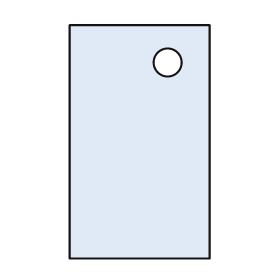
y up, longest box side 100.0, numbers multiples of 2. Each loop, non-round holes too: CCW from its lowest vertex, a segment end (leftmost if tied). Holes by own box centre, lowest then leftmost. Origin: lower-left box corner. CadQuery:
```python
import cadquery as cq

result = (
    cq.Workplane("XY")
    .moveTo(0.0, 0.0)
    .lineTo(60.0, 0.0)
    .lineTo(60.0, 100.0)
    .lineTo(0.0, 100.0)
    .close()
    .moveTo(42.0, 84.0)
    .circle(6.0)
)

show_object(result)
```